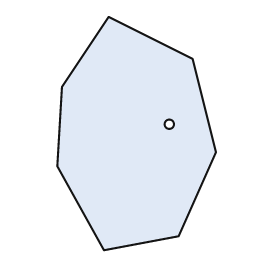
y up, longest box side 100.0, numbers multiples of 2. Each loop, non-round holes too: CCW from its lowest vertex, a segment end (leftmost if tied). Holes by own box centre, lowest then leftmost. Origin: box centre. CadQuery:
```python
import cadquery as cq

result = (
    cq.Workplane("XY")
    .moveTo(-14.0, -50.0)
    .lineTo(18.0, -44.0)
    .lineTo(34.0, -8.0)
    .lineTo(24.0, 32.0)
    .lineTo(-12.0, 50.0)
    .lineTo(-32.0, 20.0)
    .lineTo(-34.0, -14.0)
    .close()
    .moveTo(14.0, 4.0)
    .circle(2.0)
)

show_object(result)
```